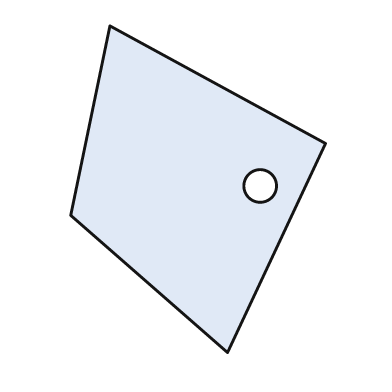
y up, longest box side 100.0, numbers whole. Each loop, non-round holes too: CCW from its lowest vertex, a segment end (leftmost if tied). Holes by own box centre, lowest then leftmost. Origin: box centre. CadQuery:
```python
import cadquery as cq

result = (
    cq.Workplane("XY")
    .moveTo(9.0, -50.0)
    .lineTo(39.0, 14.0)
    .lineTo(-27.0, 50.0)
    .lineTo(-39.0, -8.0)
    .close()
    .moveTo(19.0, 1.0)
    .circle(5.0)
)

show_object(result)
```